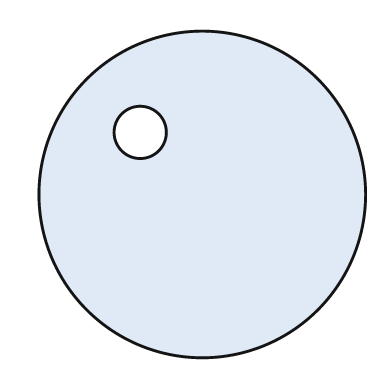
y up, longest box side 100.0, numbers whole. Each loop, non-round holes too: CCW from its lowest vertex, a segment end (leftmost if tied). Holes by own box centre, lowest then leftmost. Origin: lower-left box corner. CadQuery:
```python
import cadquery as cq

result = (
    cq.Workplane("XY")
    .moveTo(50.0, 50.0)
    .circle(50.0)
    .moveTo(31.0, 69.0)
    .circle(8.0)
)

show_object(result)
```